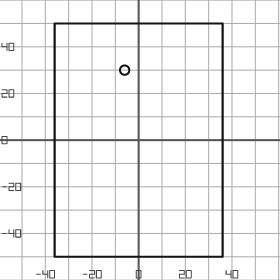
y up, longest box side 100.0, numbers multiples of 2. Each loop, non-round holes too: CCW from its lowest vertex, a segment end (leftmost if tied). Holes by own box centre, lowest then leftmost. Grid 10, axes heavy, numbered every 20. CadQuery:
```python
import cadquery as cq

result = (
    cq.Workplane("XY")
    .moveTo(-36.0, -50.0)
    .lineTo(36.0, -50.0)
    .lineTo(36.0, 50.0)
    .lineTo(-36.0, 50.0)
    .close()
    .moveTo(-6.0, 30.0)
    .circle(2.0)
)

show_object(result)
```